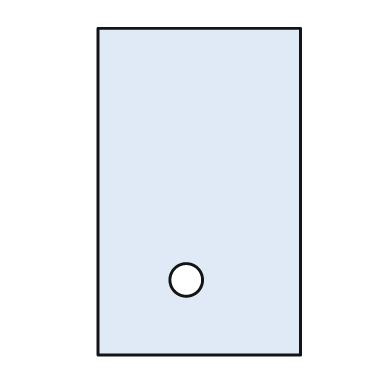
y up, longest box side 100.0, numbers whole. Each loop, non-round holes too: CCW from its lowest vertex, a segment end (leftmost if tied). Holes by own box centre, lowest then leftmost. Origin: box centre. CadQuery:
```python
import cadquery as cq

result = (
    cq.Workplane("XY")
    .moveTo(-31.0, -50.0)
    .lineTo(31.0, -50.0)
    .lineTo(31.0, 50.0)
    .lineTo(-31.0, 50.0)
    .close()
    .moveTo(-4.0, -27.0)
    .circle(5.0)
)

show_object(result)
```